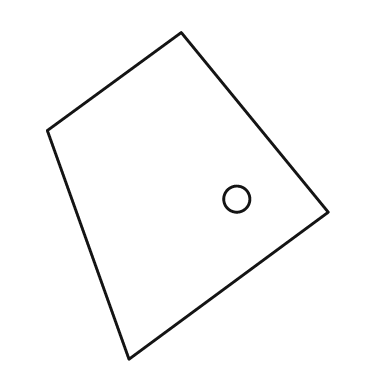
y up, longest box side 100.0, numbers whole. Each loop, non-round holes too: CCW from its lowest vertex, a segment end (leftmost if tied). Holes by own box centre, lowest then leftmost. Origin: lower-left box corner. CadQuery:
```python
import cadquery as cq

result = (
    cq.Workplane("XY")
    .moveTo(25.0, 0.0)
    .lineTo(86.0, 45.0)
    .lineTo(41.0, 100.0)
    .lineTo(0.0, 70.0)
    .close()
    .moveTo(58.0, 49.0)
    .circle(4.0)
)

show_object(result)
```